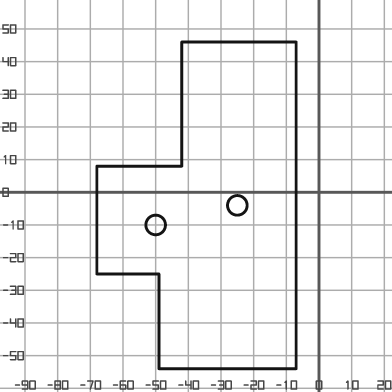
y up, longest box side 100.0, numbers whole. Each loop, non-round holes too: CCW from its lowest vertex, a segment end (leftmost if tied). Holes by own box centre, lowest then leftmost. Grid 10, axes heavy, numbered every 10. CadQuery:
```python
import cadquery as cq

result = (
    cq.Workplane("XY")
    .moveTo(-49.0, -54.0)
    .lineTo(-7.0, -54.0)
    .lineTo(-7.0, 46.0)
    .lineTo(-42.0, 46.0)
    .lineTo(-42.0, 8.0)
    .lineTo(-68.0, 8.0)
    .lineTo(-68.0, -25.0)
    .lineTo(-49.0, -25.0)
    .close()
    .moveTo(-50.0, -10.0)
    .circle(3.0)
    .moveTo(-25.0, -4.0)
    .circle(3.0)
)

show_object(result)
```